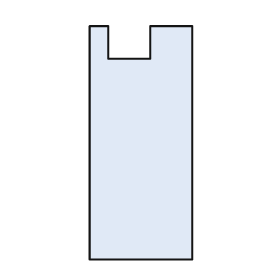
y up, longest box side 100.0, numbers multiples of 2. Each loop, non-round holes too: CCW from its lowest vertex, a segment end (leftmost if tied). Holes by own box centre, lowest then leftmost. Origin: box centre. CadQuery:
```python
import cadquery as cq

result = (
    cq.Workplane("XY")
    .moveTo(-22.0, -50.0)
    .lineTo(22.0, -50.0)
    .lineTo(22.0, 50.0)
    .lineTo(4.0, 50.0)
    .lineTo(4.0, 36.0)
    .lineTo(-14.0, 36.0)
    .lineTo(-14.0, 50.0)
    .lineTo(-22.0, 50.0)
    .close()
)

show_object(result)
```